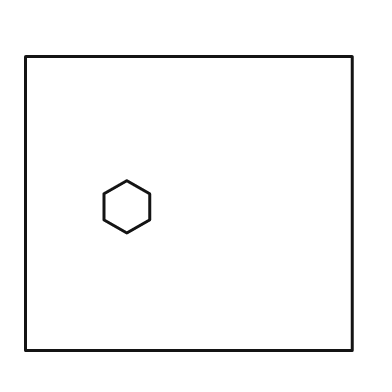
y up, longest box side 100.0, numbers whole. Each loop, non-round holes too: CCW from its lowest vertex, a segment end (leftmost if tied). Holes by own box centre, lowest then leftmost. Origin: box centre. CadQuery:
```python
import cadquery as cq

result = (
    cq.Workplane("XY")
    .moveTo(-50.0, -45.0)
    .lineTo(50.0, -45.0)
    .lineTo(50.0, 45.0)
    .lineTo(-50.0, 45.0)
    .close()
    .moveTo(-19.0, -9.0)
    .lineTo(-12.0, -5.0)
    .lineTo(-12.0, 3.0)
    .lineTo(-19.0, 7.0)
    .lineTo(-26.0, 3.0)
    .lineTo(-26.0, -5.0)
    .close()
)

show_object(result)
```